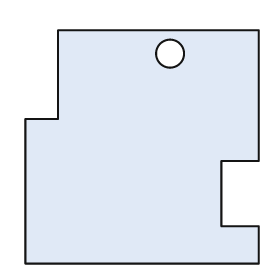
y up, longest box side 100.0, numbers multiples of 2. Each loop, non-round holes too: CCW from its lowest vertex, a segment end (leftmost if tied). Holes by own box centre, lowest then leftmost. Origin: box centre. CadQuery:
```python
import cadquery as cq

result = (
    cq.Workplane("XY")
    .moveTo(-50.0, -50.0)
    .lineTo(50.0, -50.0)
    .lineTo(50.0, -34.0)
    .lineTo(34.0, -34.0)
    .lineTo(34.0, -6.0)
    .lineTo(50.0, -6.0)
    .lineTo(50.0, 50.0)
    .lineTo(-36.0, 50.0)
    .lineTo(-36.0, 12.0)
    .lineTo(-50.0, 12.0)
    .close()
    .moveTo(12.0, 40.0)
    .circle(6.0)
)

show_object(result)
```